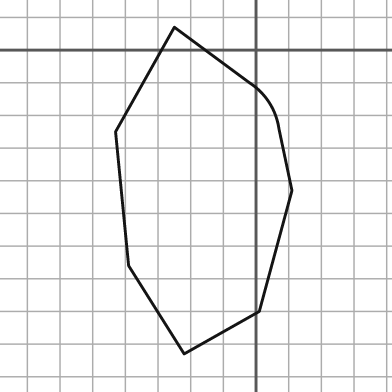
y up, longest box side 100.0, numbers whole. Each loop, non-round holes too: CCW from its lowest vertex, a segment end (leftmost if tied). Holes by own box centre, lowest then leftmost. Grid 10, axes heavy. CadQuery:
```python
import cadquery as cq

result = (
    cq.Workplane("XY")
    .moveTo(-22.0, -93.0)
    .lineTo(1.0, -80.0)
    .lineTo(11.0, -43.0)
    .lineTo(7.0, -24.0)
    .threePointArc((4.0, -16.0), (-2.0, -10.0))
    .lineTo(-25.0, 7.0)
    .lineTo(-43.0, -25.0)
    .lineTo(-39.0, -66.0)
    .close()
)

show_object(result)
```